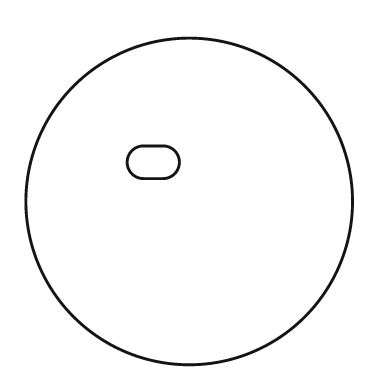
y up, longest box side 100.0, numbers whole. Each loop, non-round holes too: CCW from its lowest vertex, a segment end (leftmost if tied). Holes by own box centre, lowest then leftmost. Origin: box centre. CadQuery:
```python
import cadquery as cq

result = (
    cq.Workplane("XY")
    .moveTo(0.0, 0.0)
    .circle(50.0)
    .moveTo(-14.0, 7.0)
    .lineTo(-8.0, 7.0)
    .threePointArc((-3.0, 12.0), (-8.0, 17.0))
    .lineTo(-14.0, 17.0)
    .threePointArc((-19.0, 12.0), (-14.0, 7.0))
    .close()
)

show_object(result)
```